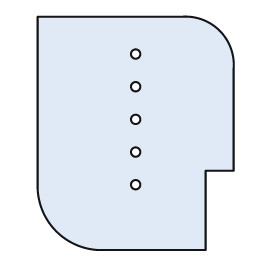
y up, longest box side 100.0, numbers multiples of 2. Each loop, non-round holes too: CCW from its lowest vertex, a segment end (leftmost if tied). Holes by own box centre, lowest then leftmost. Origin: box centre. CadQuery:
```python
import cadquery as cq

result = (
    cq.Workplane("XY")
    .moveTo(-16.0, -50.0)
    .lineTo(30.0, -50.0)
    .lineTo(30.0, -16.0)
    .lineTo(42.0, -16.0)
    .lineTo(42.0, 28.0)
    .threePointArc((36.0, 44.0), (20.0, 50.0))
    .lineTo(-42.0, 50.0)
    .lineTo(-42.0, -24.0)
    .threePointArc((-34.0, -42.0), (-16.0, -50.0))
    .close()
    .moveTo(0.0, -22.0)
    .circle(2.0)
    .moveTo(0.0, -8.0)
    .circle(2.0)
    .moveTo(0.0, 6.0)
    .circle(2.0)
    .moveTo(0.0, 20.0)
    .circle(2.0)
    .moveTo(0.0, 34.0)
    .circle(2.0)
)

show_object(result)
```